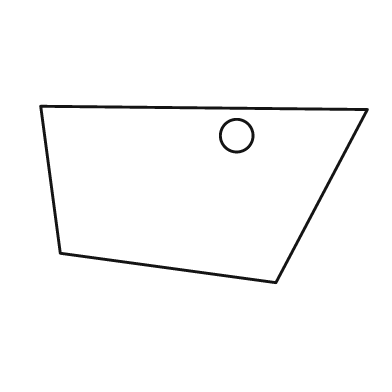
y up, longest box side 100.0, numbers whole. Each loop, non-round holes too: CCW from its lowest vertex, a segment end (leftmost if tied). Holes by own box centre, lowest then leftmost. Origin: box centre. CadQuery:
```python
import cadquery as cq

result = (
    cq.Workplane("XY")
    .moveTo(22.0, -27.0)
    .lineTo(50.0, 26.0)
    .lineTo(-50.0, 27.0)
    .lineTo(-44.0, -18.0)
    .close()
    .moveTo(10.0, 18.0)
    .circle(5.0)
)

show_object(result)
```